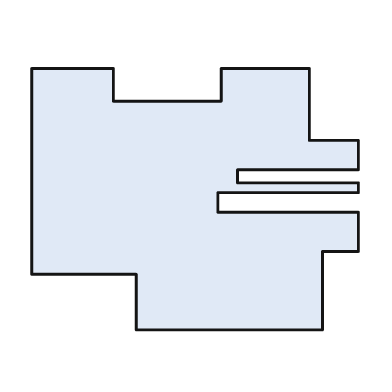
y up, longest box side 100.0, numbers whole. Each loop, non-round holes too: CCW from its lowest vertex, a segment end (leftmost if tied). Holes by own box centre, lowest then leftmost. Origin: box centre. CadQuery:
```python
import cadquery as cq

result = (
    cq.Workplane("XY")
    .moveTo(-18.0, -40.0)
    .lineTo(39.0, -40.0)
    .lineTo(39.0, -16.0)
    .lineTo(50.0, -16.0)
    .lineTo(50.0, -4.0)
    .lineTo(7.0, -4.0)
    .lineTo(7.0, 2.0)
    .lineTo(50.0, 2.0)
    .lineTo(50.0, 5.0)
    .lineTo(13.0, 5.0)
    .lineTo(13.0, 9.0)
    .lineTo(50.0, 9.0)
    .lineTo(50.0, 18.0)
    .lineTo(35.0, 18.0)
    .lineTo(35.0, 40.0)
    .lineTo(8.0, 40.0)
    .lineTo(8.0, 30.0)
    .lineTo(-25.0, 30.0)
    .lineTo(-25.0, 40.0)
    .lineTo(-50.0, 40.0)
    .lineTo(-50.0, -23.0)
    .lineTo(-18.0, -23.0)
    .close()
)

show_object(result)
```